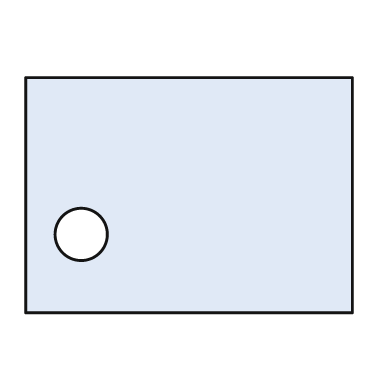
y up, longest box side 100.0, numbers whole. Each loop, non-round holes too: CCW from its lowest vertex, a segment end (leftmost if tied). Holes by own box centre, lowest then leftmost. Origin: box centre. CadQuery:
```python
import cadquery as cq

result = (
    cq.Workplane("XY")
    .moveTo(-50.0, -36.0)
    .lineTo(50.0, -36.0)
    .lineTo(50.0, 36.0)
    .lineTo(-50.0, 36.0)
    .close()
    .moveTo(-33.0, -12.0)
    .circle(8.0)
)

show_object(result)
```